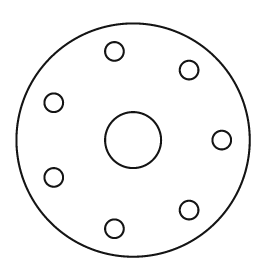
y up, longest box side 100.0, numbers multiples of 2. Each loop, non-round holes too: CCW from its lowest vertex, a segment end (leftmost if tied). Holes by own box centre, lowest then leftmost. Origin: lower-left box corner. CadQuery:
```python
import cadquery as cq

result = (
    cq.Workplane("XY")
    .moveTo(50.0, 50.0)
    .circle(50.0)
    .moveTo(42.0, 12.0)
    .circle(4.0)
    .moveTo(74.0, 20.0)
    .circle(4.0)
    .moveTo(16.0, 34.0)
    .circle(4.0)
    .moveTo(50.0, 50.0)
    .circle(12.0)
    .moveTo(88.0, 50.0)
    .circle(4.0)
    .moveTo(16.0, 66.0)
    .circle(4.0)
    .moveTo(74.0, 80.0)
    .circle(4.0)
    .moveTo(42.0, 88.0)
    .circle(4.0)
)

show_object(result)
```